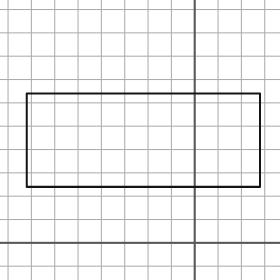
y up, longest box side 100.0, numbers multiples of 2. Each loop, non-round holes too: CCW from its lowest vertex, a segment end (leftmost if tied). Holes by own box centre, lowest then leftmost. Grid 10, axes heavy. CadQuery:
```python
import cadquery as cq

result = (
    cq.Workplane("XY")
    .moveTo(-72.0, 24.0)
    .lineTo(28.0, 24.0)
    .lineTo(28.0, 64.0)
    .lineTo(-72.0, 64.0)
    .close()
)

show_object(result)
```